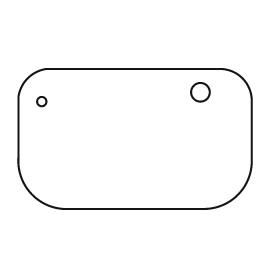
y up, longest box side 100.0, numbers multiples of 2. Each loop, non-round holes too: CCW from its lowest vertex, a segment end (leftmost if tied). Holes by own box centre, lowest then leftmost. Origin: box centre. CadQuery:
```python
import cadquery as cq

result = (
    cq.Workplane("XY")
    .moveTo(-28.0, -30.0)
    .lineTo(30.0, -30.0)
    .threePointArc((44.0, -24.0), (50.0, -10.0))
    .lineTo(50.0, 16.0)
    .threePointArc((46.0, 26.0), (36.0, 30.0))
    .lineTo(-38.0, 30.0)
    .threePointArc((-46.0, 26.0), (-50.0, 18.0))
    .lineTo(-50.0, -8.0)
    .threePointArc((-44.0, -24.0), (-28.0, -30.0))
    .close()
    .moveTo(-40.0, 16.0)
    .circle(2.0)
    .moveTo(28.0, 20.0)
    .circle(4.0)
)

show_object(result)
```